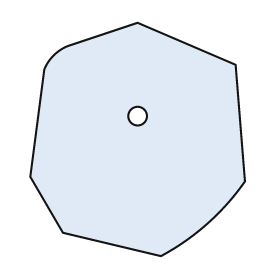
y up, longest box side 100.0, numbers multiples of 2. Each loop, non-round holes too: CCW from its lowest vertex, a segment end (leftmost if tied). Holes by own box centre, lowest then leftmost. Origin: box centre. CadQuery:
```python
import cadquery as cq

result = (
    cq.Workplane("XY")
    .moveTo(10.0, -50.0)
    .threePointArc((30.0, -36.0), (46.0, -18.0))
    .lineTo(42.0, 32.0)
    .lineTo(0.0, 50.0)
    .lineTo(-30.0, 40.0)
    .threePointArc((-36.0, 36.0), (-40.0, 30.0))
    .lineTo(-46.0, -16.0)
    .lineTo(-32.0, -40.0)
    .close()
    .moveTo(0.0, 10.0)
    .circle(4.0)
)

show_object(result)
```